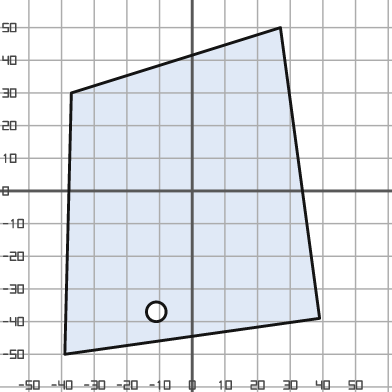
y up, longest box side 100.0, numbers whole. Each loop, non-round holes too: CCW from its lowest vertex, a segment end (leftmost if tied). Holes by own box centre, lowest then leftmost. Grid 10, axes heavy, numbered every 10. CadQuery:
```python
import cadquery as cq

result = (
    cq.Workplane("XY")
    .moveTo(-39.0, -50.0)
    .lineTo(39.0, -39.0)
    .lineTo(27.0, 50.0)
    .lineTo(-37.0, 30.0)
    .close()
    .moveTo(-11.0, -37.0)
    .circle(3.0)
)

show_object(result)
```